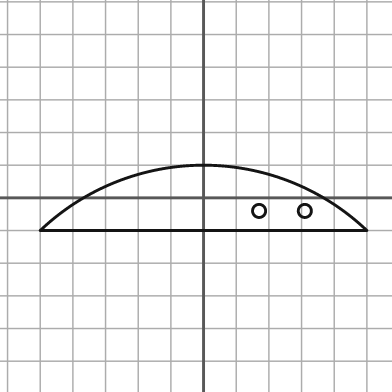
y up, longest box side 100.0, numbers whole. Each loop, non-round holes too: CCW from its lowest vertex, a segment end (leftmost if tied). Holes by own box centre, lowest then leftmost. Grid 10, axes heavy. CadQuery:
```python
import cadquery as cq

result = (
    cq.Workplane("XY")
    .moveTo(-50.0, -10.0)
    .lineTo(50.0, -10.0)
    .threePointArc((0.0, 10.0), (-50.0, -10.0))
    .close()
    .moveTo(17.0, -4.0)
    .circle(2.0)
    .moveTo(31.0, -4.0)
    .circle(2.0)
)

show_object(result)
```